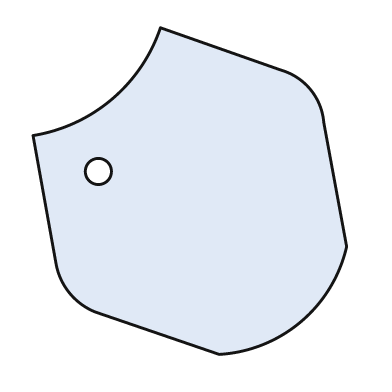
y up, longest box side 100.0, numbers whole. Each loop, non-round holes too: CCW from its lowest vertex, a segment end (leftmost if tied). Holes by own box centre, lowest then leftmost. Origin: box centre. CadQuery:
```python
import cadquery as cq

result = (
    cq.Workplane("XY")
    .moveTo(9.0, -50.0)
    .threePointArc((34.0, -40.0), (48.0, -17.0))
    .lineTo(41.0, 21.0)
    .threePointArc((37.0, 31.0), (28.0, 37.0))
    .lineTo(-9.0, 50.0)
    .threePointArc((-24.0, 28.0), (-48.0, 17.0))
    .lineTo(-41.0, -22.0)
    .threePointArc((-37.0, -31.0), (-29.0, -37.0))
    .close()
    .moveTo(-28.0, 6.0)
    .circle(4.0)
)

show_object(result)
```